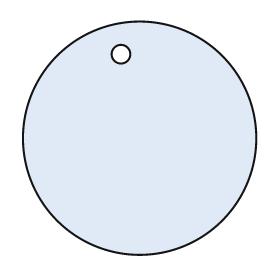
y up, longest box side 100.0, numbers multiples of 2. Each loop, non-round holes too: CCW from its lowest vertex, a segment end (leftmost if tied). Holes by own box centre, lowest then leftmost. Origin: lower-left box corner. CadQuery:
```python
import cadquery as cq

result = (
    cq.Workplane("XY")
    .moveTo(50.0, 50.0)
    .circle(50.0)
    .moveTo(42.0, 86.0)
    .circle(4.0)
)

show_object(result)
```